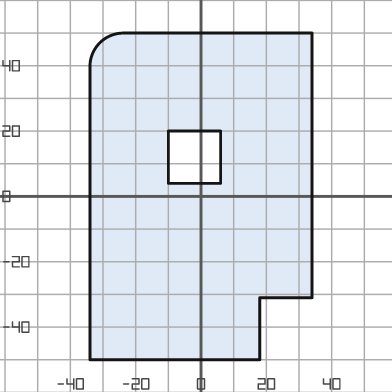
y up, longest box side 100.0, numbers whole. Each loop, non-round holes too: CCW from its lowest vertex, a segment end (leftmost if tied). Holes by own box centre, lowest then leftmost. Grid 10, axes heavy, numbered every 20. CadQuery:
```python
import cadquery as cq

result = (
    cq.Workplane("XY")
    .moveTo(-34.0, -50.0)
    .lineTo(18.0, -50.0)
    .lineTo(18.0, -31.0)
    .lineTo(34.0, -31.0)
    .lineTo(34.0, 50.0)
    .lineTo(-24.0, 50.0)
    .threePointArc((-31.0, 47.0), (-34.0, 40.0))
    .close()
    .moveTo(-10.0, 4.0)
    .lineTo(6.0, 4.0)
    .lineTo(6.0, 20.0)
    .lineTo(-10.0, 20.0)
    .close()
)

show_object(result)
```